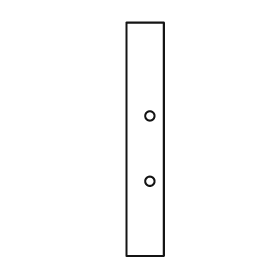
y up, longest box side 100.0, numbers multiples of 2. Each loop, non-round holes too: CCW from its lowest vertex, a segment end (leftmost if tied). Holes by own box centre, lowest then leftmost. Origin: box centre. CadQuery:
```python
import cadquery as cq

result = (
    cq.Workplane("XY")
    .moveTo(-8.0, -50.0)
    .lineTo(8.0, -50.0)
    .lineTo(8.0, 50.0)
    .lineTo(-8.0, 50.0)
    .close()
    .moveTo(2.0, -18.0)
    .circle(2.0)
    .moveTo(2.0, 10.0)
    .circle(2.0)
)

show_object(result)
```